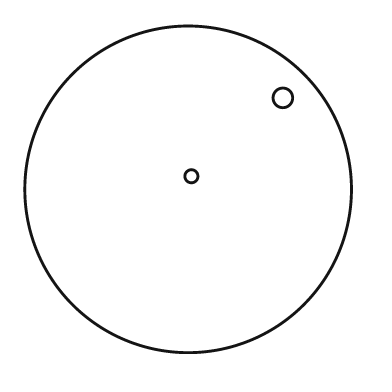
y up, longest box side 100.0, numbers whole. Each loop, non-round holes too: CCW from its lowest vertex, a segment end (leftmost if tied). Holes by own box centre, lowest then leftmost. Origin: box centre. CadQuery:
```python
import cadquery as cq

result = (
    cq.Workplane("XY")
    .moveTo(0.0, 0.0)
    .circle(50.0)
    .moveTo(1.0, 4.0)
    .circle(2.0)
    .moveTo(29.0, 28.0)
    .circle(3.0)
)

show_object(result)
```